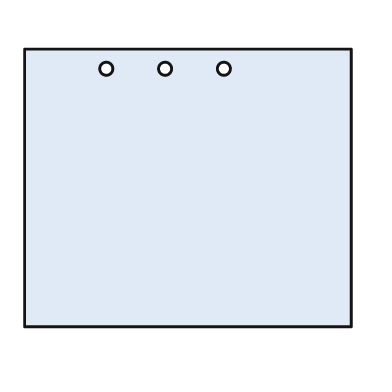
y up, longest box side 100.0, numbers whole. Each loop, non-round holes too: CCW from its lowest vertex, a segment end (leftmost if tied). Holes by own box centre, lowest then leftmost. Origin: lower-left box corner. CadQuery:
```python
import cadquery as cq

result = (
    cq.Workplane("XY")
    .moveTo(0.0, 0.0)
    .lineTo(100.0, 0.0)
    .lineTo(100.0, 85.0)
    .lineTo(0.0, 85.0)
    .close()
    .moveTo(25.0, 79.0)
    .circle(2.0)
    .moveTo(43.0, 79.0)
    .circle(2.0)
    .moveTo(61.0, 79.0)
    .circle(2.0)
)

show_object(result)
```